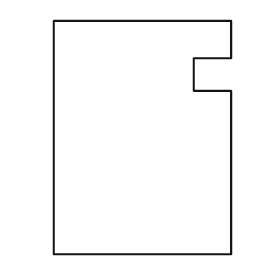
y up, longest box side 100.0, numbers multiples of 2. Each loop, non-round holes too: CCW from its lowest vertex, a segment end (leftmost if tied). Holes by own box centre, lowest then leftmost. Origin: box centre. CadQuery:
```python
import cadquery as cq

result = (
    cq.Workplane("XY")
    .moveTo(-38.0, -50.0)
    .lineTo(38.0, -50.0)
    .lineTo(38.0, 20.0)
    .lineTo(22.0, 20.0)
    .lineTo(22.0, 34.0)
    .lineTo(38.0, 34.0)
    .lineTo(38.0, 50.0)
    .lineTo(-38.0, 50.0)
    .close()
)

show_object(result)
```